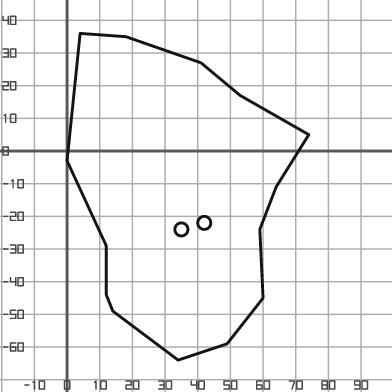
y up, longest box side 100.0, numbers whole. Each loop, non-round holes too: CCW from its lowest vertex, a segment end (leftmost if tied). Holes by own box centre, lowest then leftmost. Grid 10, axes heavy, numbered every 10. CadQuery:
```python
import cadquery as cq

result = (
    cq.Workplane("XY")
    .moveTo(34.0, -64.0)
    .lineTo(49.0, -59.0)
    .lineTo(60.0, -45.0)
    .lineTo(59.0, -24.0)
    .lineTo(64.0, -11.0)
    .lineTo(74.0, 5.0)
    .lineTo(53.0, 17.0)
    .lineTo(41.0, 27.0)
    .lineTo(18.0, 35.0)
    .lineTo(4.0, 36.0)
    .lineTo(0.0, -3.0)
    .lineTo(12.0, -29.0)
    .lineTo(12.0, -44.0)
    .lineTo(14.0, -49.0)
    .close()
    .moveTo(35.0, -24.0)
    .circle(2.0)
    .moveTo(42.0, -22.0)
    .circle(2.0)
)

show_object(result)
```